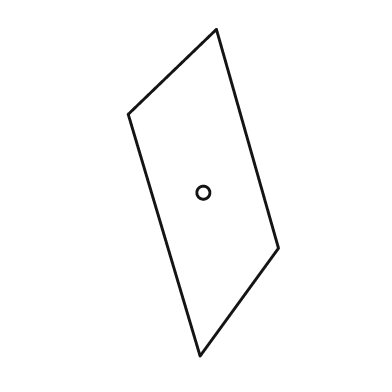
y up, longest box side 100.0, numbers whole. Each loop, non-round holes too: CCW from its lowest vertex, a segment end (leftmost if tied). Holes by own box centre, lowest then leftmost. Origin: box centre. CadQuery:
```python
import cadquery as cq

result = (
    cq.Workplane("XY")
    .moveTo(-1.0, -50.0)
    .lineTo(23.0, -17.0)
    .lineTo(4.0, 50.0)
    .lineTo(-23.0, 24.0)
    .close()
    .moveTo(0.0, 0.0)
    .circle(2.0)
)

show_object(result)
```